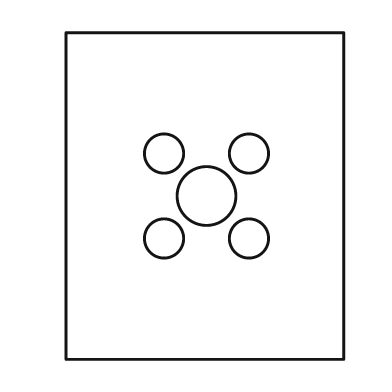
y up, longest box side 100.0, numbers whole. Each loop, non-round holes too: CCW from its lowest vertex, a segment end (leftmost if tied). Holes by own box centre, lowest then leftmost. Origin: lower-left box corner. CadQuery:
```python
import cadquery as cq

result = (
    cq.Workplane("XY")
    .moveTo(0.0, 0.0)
    .lineTo(85.0, 0.0)
    .lineTo(85.0, 100.0)
    .lineTo(0.0, 100.0)
    .close()
    .moveTo(30.0, 37.0)
    .circle(6.0)
    .moveTo(56.0, 37.0)
    .circle(6.0)
    .moveTo(43.0, 50.0)
    .circle(9.0)
    .moveTo(30.0, 63.0)
    .circle(6.0)
    .moveTo(56.0, 63.0)
    .circle(6.0)
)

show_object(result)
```